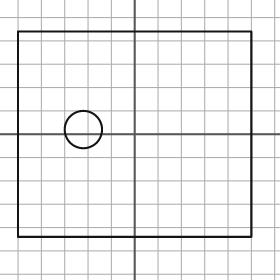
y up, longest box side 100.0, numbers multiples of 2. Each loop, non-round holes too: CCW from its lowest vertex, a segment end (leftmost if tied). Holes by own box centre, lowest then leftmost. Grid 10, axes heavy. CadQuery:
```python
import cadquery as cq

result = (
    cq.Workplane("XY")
    .moveTo(-50.0, -44.0)
    .lineTo(50.0, -44.0)
    .lineTo(50.0, 44.0)
    .lineTo(-50.0, 44.0)
    .close()
    .moveTo(-22.0, 2.0)
    .circle(8.0)
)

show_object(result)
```